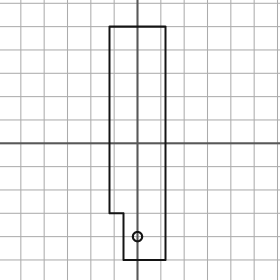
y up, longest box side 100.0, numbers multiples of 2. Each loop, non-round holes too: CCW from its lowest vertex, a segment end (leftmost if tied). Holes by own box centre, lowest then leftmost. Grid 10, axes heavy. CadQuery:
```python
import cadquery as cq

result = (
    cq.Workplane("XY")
    .moveTo(-6.0, -50.0)
    .lineTo(12.0, -50.0)
    .lineTo(12.0, 50.0)
    .lineTo(-12.0, 50.0)
    .lineTo(-12.0, -30.0)
    .lineTo(-6.0, -30.0)
    .close()
    .moveTo(0.0, -40.0)
    .circle(2.0)
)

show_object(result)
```